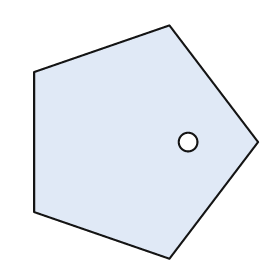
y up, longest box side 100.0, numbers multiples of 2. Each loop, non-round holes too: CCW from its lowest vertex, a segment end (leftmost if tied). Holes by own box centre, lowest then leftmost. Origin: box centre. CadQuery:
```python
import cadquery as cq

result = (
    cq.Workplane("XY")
    .moveTo(10.0, -50.0)
    .lineTo(48.0, 0.0)
    .lineTo(10.0, 50.0)
    .lineTo(-48.0, 30.0)
    .lineTo(-48.0, -30.0)
    .close()
    .moveTo(18.0, 0.0)
    .circle(4.0)
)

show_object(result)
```